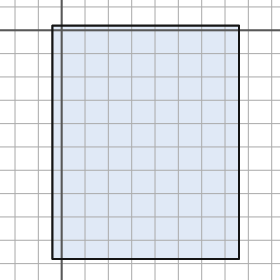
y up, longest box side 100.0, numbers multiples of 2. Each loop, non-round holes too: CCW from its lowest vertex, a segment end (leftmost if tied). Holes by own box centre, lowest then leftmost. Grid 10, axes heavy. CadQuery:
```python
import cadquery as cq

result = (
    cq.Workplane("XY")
    .moveTo(-4.0, -98.0)
    .lineTo(76.0, -98.0)
    .lineTo(76.0, 2.0)
    .lineTo(-4.0, 2.0)
    .close()
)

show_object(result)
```